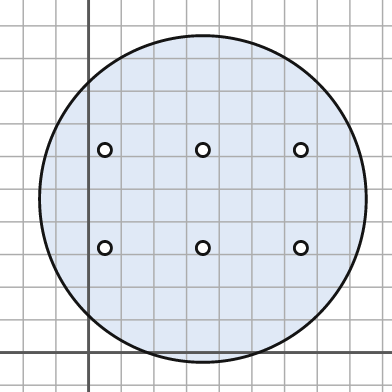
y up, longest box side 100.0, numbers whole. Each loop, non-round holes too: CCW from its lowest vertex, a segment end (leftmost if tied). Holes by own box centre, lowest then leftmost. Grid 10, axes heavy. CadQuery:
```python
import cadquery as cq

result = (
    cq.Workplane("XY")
    .moveTo(35.0, 47.0)
    .circle(50.0)
    .moveTo(5.0, 32.0)
    .circle(2.0)
    .moveTo(35.0, 32.0)
    .circle(2.0)
    .moveTo(65.0, 32.0)
    .circle(2.0)
    .moveTo(5.0, 62.0)
    .circle(2.0)
    .moveTo(35.0, 62.0)
    .circle(2.0)
    .moveTo(65.0, 62.0)
    .circle(2.0)
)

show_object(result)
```